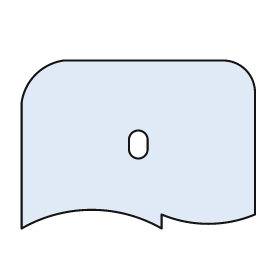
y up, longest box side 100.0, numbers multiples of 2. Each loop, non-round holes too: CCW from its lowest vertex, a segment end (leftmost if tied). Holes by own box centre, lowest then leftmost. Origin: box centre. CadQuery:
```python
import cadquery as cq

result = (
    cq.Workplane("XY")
    .moveTo(-50.0, -36.0)
    .threePointArc((-20.0, -28.0), (10.0, -36.0))
    .lineTo(10.0, -30.0)
    .threePointArc((30.0, -34.0), (50.0, -30.0))
    .lineTo(50.0, 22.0)
    .threePointArc((46.0, 32.0), (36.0, 36.0))
    .lineTo(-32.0, 36.0)
    .threePointArc((-44.0, 30.0), (-50.0, 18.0))
    .close()
    .moveTo(-4.0, -2.0)
    .threePointArc((0.0, -6.0), (4.0, -2.0))
    .lineTo(4.0, 2.0)
    .threePointArc((0.0, 6.0), (-4.0, 2.0))
    .close()
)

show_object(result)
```